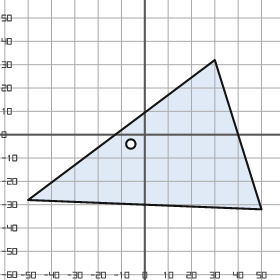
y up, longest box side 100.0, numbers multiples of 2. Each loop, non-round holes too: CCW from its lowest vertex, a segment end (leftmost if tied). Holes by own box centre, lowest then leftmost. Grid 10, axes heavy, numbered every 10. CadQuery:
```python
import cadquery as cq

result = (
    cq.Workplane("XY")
    .moveTo(50.0, -32.0)
    .lineTo(30.0, 32.0)
    .lineTo(-50.0, -28.0)
    .close()
    .moveTo(-6.0, -4.0)
    .circle(2.0)
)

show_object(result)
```